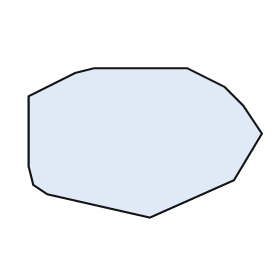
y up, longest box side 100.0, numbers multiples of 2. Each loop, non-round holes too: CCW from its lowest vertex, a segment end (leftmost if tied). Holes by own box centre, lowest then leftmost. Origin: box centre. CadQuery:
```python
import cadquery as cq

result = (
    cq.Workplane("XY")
    .moveTo(2.0, -32.0)
    .lineTo(38.0, -16.0)
    .lineTo(50.0, 4.0)
    .lineTo(42.0, 16.0)
    .lineTo(34.0, 24.0)
    .lineTo(18.0, 32.0)
    .lineTo(-22.0, 32.0)
    .lineTo(-30.0, 30.0)
    .lineTo(-50.0, 20.0)
    .lineTo(-50.0, -10.0)
    .lineTo(-48.0, -18.0)
    .lineTo(-42.0, -22.0)
    .close()
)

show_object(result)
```